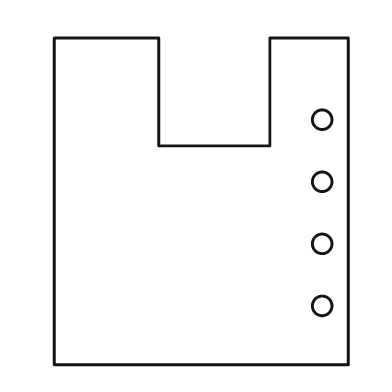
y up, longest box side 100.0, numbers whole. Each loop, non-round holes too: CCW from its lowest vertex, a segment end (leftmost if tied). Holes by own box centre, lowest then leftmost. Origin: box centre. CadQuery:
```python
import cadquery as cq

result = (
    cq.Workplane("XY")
    .moveTo(-45.0, -50.0)
    .lineTo(45.0, -50.0)
    .lineTo(45.0, 50.0)
    .lineTo(21.0, 50.0)
    .lineTo(21.0, 17.0)
    .lineTo(-13.0, 17.0)
    .lineTo(-13.0, 50.0)
    .lineTo(-45.0, 50.0)
    .close()
    .moveTo(37.0, -32.0)
    .circle(3.0)
    .moveTo(37.0, -13.0)
    .circle(3.0)
    .moveTo(37.0, 6.0)
    .circle(3.0)
    .moveTo(37.0, 25.0)
    .circle(3.0)
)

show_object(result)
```